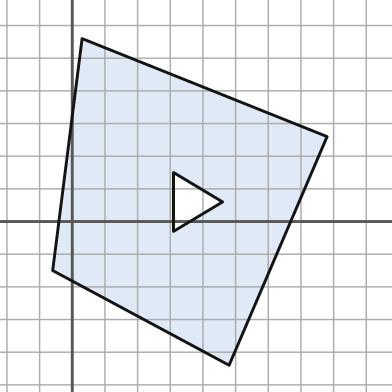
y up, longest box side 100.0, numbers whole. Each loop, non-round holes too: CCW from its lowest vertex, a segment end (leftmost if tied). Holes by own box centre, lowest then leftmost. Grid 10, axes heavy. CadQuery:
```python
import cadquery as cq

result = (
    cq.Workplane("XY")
    .moveTo(48.0, -44.0)
    .lineTo(78.0, 26.0)
    .lineTo(3.0, 56.0)
    .lineTo(-6.0, -15.0)
    .close()
    .moveTo(31.0, -3.0)
    .lineTo(46.0, 6.0)
    .lineTo(31.0, 15.0)
    .close()
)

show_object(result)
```